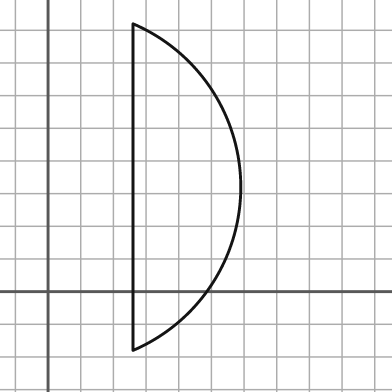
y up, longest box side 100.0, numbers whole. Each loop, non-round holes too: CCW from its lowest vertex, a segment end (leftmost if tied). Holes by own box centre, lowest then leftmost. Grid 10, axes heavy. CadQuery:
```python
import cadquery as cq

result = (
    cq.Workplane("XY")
    .moveTo(26.0, -18.0)
    .threePointArc((59.0, 32.0), (26.0, 82.0))
    .close()
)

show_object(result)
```